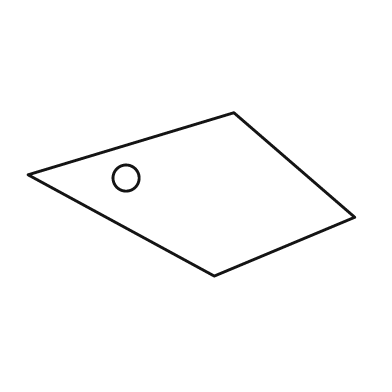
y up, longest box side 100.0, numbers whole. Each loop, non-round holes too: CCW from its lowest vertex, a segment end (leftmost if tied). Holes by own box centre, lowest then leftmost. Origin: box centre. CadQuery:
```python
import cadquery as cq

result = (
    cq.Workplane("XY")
    .moveTo(7.0, -25.0)
    .lineTo(50.0, -7.0)
    .lineTo(13.0, 25.0)
    .lineTo(-50.0, 6.0)
    .close()
    .moveTo(-20.0, 5.0)
    .circle(4.0)
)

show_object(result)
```